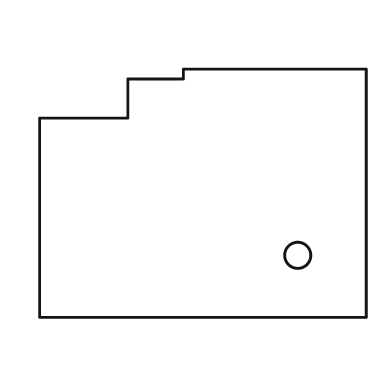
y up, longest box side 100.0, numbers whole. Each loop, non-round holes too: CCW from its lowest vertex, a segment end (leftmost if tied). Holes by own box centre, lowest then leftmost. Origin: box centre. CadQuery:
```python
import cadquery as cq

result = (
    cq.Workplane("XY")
    .moveTo(-50.0, -38.0)
    .lineTo(50.0, -38.0)
    .lineTo(50.0, 38.0)
    .lineTo(-6.0, 38.0)
    .lineTo(-6.0, 35.0)
    .lineTo(-23.0, 35.0)
    .lineTo(-23.0, 23.0)
    .lineTo(-50.0, 23.0)
    .close()
    .moveTo(29.0, -19.0)
    .circle(4.0)
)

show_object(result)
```